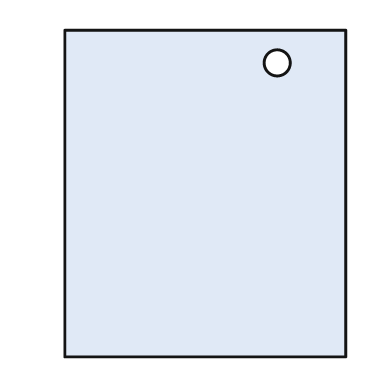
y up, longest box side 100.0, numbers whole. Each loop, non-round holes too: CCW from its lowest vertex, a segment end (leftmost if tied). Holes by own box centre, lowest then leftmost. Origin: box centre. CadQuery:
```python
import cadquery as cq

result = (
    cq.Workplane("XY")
    .moveTo(-43.0, -50.0)
    .lineTo(43.0, -50.0)
    .lineTo(43.0, 50.0)
    .lineTo(-43.0, 50.0)
    .close()
    .moveTo(22.0, 40.0)
    .circle(4.0)
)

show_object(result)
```